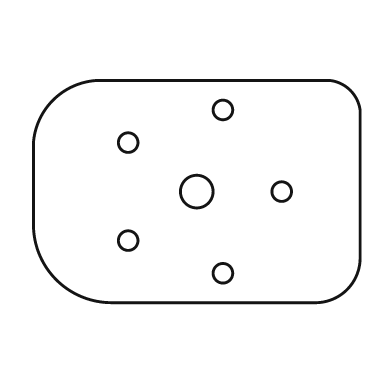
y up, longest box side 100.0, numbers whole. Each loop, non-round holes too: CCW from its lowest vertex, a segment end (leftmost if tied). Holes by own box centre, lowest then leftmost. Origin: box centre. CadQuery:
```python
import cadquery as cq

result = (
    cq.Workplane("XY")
    .moveTo(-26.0, -34.0)
    .lineTo(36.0, -34.0)
    .threePointArc((46.0, -30.0), (50.0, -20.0))
    .lineTo(50.0, 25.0)
    .threePointArc((47.0, 31.0), (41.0, 34.0))
    .lineTo(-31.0, 34.0)
    .threePointArc((-44.0, 28.0), (-50.0, 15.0))
    .lineTo(-50.0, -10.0)
    .threePointArc((-43.0, -27.0), (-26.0, -34.0))
    .close()
    .moveTo(8.0, -25.0)
    .circle(3.0)
    .moveTo(-21.0, -15.0)
    .circle(3.0)
    .moveTo(0.0, 0.0)
    .circle(5.0)
    .moveTo(26.0, 0.0)
    .circle(3.0)
    .moveTo(-21.0, 15.0)
    .circle(3.0)
    .moveTo(8.0, 25.0)
    .circle(3.0)
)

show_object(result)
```